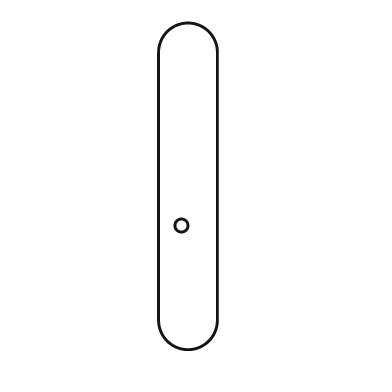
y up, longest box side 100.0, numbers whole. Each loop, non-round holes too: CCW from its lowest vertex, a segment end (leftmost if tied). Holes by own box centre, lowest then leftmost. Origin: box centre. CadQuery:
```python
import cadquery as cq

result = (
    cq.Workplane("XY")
    .moveTo(-9.0, -41.0)
    .threePointArc((0.0, -50.0), (9.0, -41.0))
    .lineTo(9.0, 41.0)
    .threePointArc((0.0, 50.0), (-9.0, 41.0))
    .close()
    .moveTo(-2.0, -12.0)
    .circle(2.0)
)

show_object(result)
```